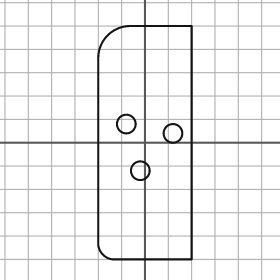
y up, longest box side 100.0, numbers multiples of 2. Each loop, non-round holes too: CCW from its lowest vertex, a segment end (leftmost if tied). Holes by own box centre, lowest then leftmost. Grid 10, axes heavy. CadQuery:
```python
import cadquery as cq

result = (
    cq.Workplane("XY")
    .moveTo(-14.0, -50.0)
    .lineTo(20.0, -50.0)
    .lineTo(20.0, 50.0)
    .lineTo(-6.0, 50.0)
    .threePointArc((-16.0, 46.0), (-20.0, 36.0))
    .lineTo(-20.0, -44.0)
    .threePointArc((-18.0, -48.0), (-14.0, -50.0))
    .close()
    .moveTo(-2.0, -12.0)
    .circle(4.0)
    .moveTo(12.0, 4.0)
    .circle(4.0)
    .moveTo(-8.0, 8.0)
    .circle(4.0)
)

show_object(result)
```